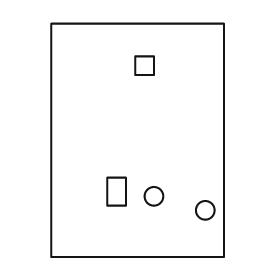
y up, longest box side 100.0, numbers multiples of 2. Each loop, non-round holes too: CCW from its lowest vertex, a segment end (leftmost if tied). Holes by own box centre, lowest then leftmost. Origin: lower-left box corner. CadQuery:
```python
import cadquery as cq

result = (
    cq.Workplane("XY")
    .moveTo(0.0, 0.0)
    .lineTo(74.0, 0.0)
    .lineTo(74.0, 100.0)
    .lineTo(0.0, 100.0)
    .close()
    .moveTo(66.0, 20.0)
    .circle(4.0)
    .moveTo(44.0, 26.0)
    .circle(4.0)
    .moveTo(24.0, 22.0)
    .lineTo(32.0, 22.0)
    .lineTo(32.0, 34.0)
    .lineTo(24.0, 34.0)
    .close()
    .moveTo(36.0, 78.0)
    .lineTo(44.0, 78.0)
    .lineTo(44.0, 86.0)
    .lineTo(36.0, 86.0)
    .close()
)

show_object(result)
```